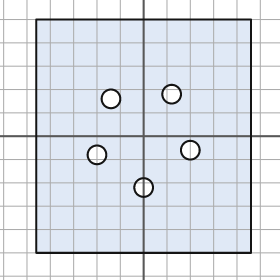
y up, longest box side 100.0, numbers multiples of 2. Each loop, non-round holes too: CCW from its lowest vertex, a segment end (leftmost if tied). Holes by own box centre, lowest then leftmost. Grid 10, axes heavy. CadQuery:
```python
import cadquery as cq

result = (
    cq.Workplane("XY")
    .moveTo(-46.0, -50.0)
    .lineTo(46.0, -50.0)
    .lineTo(46.0, 50.0)
    .lineTo(-46.0, 50.0)
    .close()
    .moveTo(0.0, -22.0)
    .circle(4.0)
    .moveTo(-20.0, -8.0)
    .circle(4.0)
    .moveTo(20.0, -6.0)
    .circle(4.0)
    .moveTo(-14.0, 16.0)
    .circle(4.0)
    .moveTo(12.0, 18.0)
    .circle(4.0)
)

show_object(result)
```